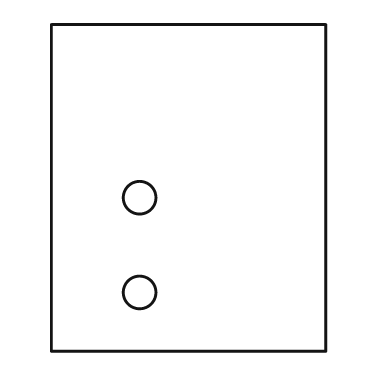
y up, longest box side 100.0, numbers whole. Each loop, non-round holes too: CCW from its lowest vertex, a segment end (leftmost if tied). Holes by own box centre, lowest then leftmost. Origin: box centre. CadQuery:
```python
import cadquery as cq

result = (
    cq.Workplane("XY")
    .moveTo(-42.0, -50.0)
    .lineTo(42.0, -50.0)
    .lineTo(42.0, 50.0)
    .lineTo(-42.0, 50.0)
    .close()
    .moveTo(-15.0, -32.0)
    .circle(5.0)
    .moveTo(-15.0, -3.0)
    .circle(5.0)
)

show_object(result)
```